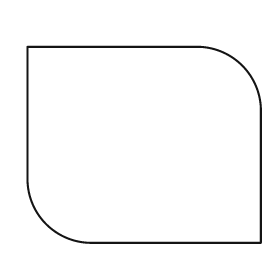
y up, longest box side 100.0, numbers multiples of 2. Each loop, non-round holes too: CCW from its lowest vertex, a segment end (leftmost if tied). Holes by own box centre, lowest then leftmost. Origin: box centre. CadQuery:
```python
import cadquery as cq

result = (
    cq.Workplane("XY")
    .moveTo(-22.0, -42.0)
    .lineTo(50.0, -42.0)
    .lineTo(50.0, 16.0)
    .threePointArc((42.0, 34.0), (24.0, 42.0))
    .lineTo(-50.0, 42.0)
    .lineTo(-50.0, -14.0)
    .threePointArc((-42.0, -34.0), (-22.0, -42.0))
    .close()
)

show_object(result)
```